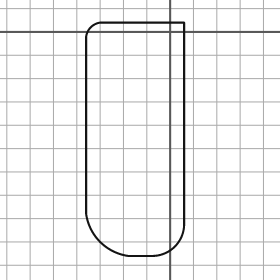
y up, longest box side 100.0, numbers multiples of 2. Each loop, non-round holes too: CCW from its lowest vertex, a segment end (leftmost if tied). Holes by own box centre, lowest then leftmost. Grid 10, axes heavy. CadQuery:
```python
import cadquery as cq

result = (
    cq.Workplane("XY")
    .moveTo(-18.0, -96.0)
    .lineTo(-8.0, -96.0)
    .threePointArc((2.0, -92.0), (6.0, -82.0))
    .lineTo(6.0, 4.0)
    .lineTo(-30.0, 4.0)
    .threePointArc((-34.0, 2.0), (-36.0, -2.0))
    .lineTo(-36.0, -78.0)
    .threePointArc((-30.0, -90.0), (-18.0, -96.0))
    .close()
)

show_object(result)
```